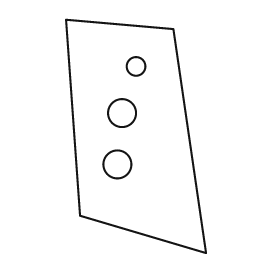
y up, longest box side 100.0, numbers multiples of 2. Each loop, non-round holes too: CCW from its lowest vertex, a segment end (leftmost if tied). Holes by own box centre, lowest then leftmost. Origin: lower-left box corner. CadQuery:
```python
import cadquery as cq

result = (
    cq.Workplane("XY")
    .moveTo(60.0, 0.0)
    .lineTo(46.0, 96.0)
    .lineTo(0.0, 100.0)
    .lineTo(6.0, 16.0)
    .close()
    .moveTo(22.0, 38.0)
    .circle(6.0)
    .moveTo(24.0, 60.0)
    .circle(6.0)
    .moveTo(30.0, 80.0)
    .circle(4.0)
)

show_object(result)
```